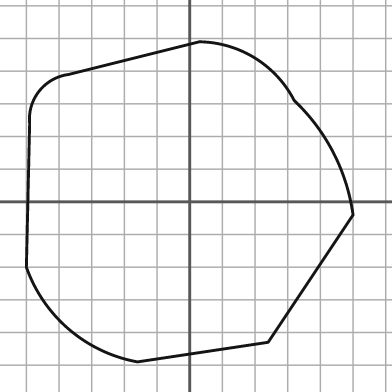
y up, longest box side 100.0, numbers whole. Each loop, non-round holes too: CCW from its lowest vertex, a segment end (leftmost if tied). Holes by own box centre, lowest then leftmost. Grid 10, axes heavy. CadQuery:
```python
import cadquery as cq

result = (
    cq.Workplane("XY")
    .moveTo(-16.0, -49.0)
    .lineTo(24.0, -43.0)
    .lineTo(50.0, -4.0)
    .threePointArc((44.0, 15.0), (32.0, 31.0))
    .threePointArc((20.0, 44.0), (3.0, 49.0))
    .lineTo(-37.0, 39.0)
    .threePointArc((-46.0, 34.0), (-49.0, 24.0))
    .lineTo(-50.0, -20.0)
    .threePointArc((-37.0, -39.0), (-16.0, -49.0))
    .close()
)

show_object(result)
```